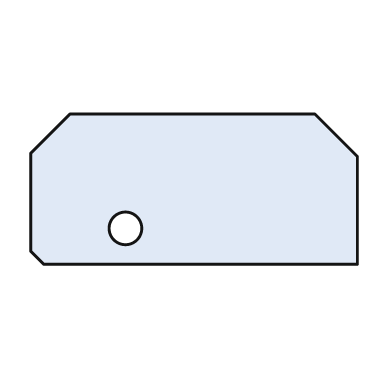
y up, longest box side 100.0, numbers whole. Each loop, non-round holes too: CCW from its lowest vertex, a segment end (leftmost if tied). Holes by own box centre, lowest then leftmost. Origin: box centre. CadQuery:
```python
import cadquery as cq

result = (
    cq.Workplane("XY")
    .moveTo(-46.0, -23.0)
    .lineTo(50.0, -23.0)
    .lineTo(50.0, 10.0)
    .lineTo(37.0, 23.0)
    .lineTo(-38.0, 23.0)
    .lineTo(-50.0, 11.0)
    .lineTo(-50.0, -19.0)
    .close()
    .moveTo(-21.0, -12.0)
    .circle(5.0)
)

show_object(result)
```